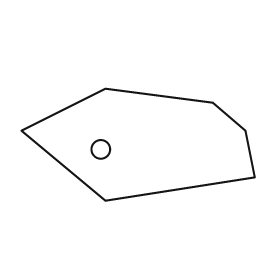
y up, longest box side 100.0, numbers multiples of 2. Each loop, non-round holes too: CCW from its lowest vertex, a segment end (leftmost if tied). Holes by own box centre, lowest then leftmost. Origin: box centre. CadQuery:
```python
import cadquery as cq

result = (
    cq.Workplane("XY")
    .moveTo(-14.0, -24.0)
    .lineTo(50.0, -14.0)
    .lineTo(46.0, 6.0)
    .lineTo(32.0, 18.0)
    .lineTo(-14.0, 24.0)
    .lineTo(-50.0, 6.0)
    .close()
    .moveTo(-16.0, -2.0)
    .circle(4.0)
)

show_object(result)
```